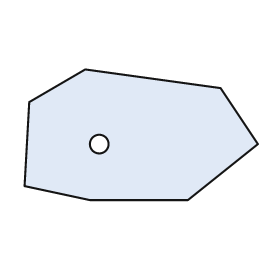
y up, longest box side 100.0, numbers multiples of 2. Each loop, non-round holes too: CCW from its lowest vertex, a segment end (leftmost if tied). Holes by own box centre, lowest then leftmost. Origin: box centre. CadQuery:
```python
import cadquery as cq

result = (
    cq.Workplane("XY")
    .moveTo(-22.0, -28.0)
    .lineTo(20.0, -28.0)
    .lineTo(50.0, -4.0)
    .lineTo(34.0, 20.0)
    .lineTo(-24.0, 28.0)
    .lineTo(-48.0, 14.0)
    .lineTo(-50.0, -22.0)
    .close()
    .moveTo(-18.0, -4.0)
    .circle(4.0)
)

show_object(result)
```